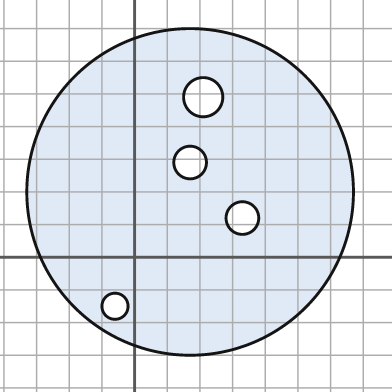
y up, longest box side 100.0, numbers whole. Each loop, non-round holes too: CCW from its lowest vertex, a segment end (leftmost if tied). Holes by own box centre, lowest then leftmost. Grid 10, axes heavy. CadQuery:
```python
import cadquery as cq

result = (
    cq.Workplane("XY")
    .moveTo(17.0, 20.0)
    .circle(50.0)
    .moveTo(-6.0, -15.0)
    .circle(4.0)
    .moveTo(33.0, 12.0)
    .circle(5.0)
    .moveTo(17.0, 29.0)
    .circle(5.0)
    .moveTo(21.0, 49.0)
    .circle(6.0)
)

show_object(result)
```